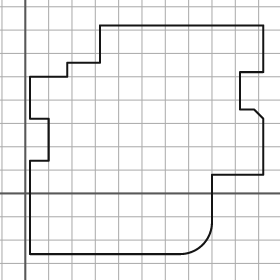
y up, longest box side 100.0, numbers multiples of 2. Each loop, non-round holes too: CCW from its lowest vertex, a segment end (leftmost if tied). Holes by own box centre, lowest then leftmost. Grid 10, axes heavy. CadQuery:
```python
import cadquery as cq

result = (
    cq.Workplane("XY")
    .moveTo(2.0, -26.0)
    .lineTo(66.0, -26.0)
    .threePointArc((76.0, -22.0), (80.0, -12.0))
    .lineTo(80.0, 8.0)
    .lineTo(102.0, 8.0)
    .lineTo(102.0, 32.0)
    .lineTo(98.0, 36.0)
    .lineTo(92.0, 36.0)
    .lineTo(92.0, 52.0)
    .lineTo(102.0, 52.0)
    .lineTo(102.0, 72.0)
    .lineTo(32.0, 72.0)
    .lineTo(32.0, 56.0)
    .lineTo(18.0, 56.0)
    .lineTo(18.0, 50.0)
    .lineTo(2.0, 50.0)
    .lineTo(2.0, 32.0)
    .lineTo(10.0, 32.0)
    .lineTo(10.0, 14.0)
    .lineTo(2.0, 14.0)
    .close()
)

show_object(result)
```